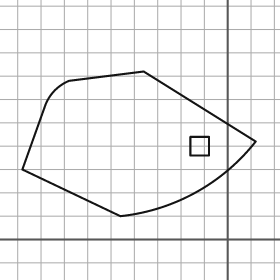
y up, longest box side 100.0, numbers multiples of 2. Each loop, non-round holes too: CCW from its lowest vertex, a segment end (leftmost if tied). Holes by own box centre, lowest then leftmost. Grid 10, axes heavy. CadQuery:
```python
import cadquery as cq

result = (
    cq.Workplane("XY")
    .moveTo(-46.0, 10.0)
    .threePointArc((-14.0, 20.0), (12.0, 42.0))
    .lineTo(-36.0, 72.0)
    .lineTo(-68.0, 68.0)
    .threePointArc((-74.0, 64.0), (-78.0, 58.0))
    .lineTo(-88.0, 30.0)
    .close()
    .moveTo(-16.0, 36.0)
    .lineTo(-8.0, 36.0)
    .lineTo(-8.0, 44.0)
    .lineTo(-16.0, 44.0)
    .close()
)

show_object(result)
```